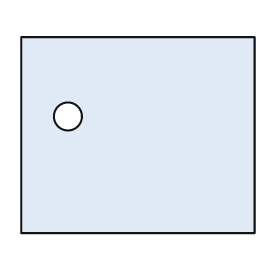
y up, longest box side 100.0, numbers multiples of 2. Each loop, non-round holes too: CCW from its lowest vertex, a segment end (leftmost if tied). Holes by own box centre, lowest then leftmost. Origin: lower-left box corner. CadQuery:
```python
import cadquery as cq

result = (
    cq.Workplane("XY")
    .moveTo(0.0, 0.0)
    .lineTo(100.0, 0.0)
    .lineTo(100.0, 84.0)
    .lineTo(0.0, 84.0)
    .close()
    .moveTo(20.0, 50.0)
    .circle(6.0)
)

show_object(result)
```